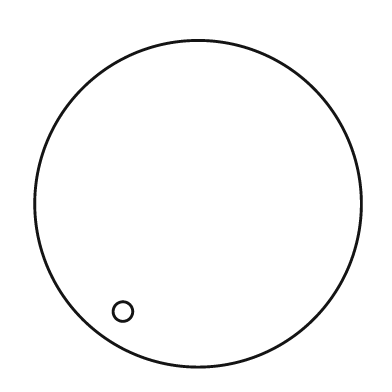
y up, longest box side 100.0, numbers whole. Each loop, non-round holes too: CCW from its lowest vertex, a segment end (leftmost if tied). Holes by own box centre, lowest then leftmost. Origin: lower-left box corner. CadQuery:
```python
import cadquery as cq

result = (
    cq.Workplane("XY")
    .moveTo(50.0, 50.0)
    .circle(50.0)
    .moveTo(27.0, 17.0)
    .circle(3.0)
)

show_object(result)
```